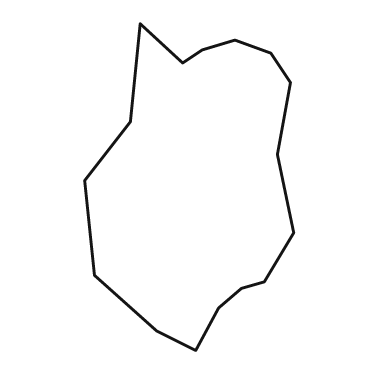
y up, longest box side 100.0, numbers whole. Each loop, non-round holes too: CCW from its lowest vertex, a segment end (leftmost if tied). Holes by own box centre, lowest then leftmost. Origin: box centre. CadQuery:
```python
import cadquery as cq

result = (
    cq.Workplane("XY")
    .moveTo(2.0, -50.0)
    .lineTo(9.0, -37.0)
    .lineTo(16.0, -31.0)
    .lineTo(23.0, -29.0)
    .lineTo(32.0, -14.0)
    .lineTo(27.0, 10.0)
    .lineTo(31.0, 32.0)
    .lineTo(25.0, 41.0)
    .lineTo(14.0, 45.0)
    .lineTo(4.0, 42.0)
    .lineTo(-2.0, 38.0)
    .lineTo(-15.0, 50.0)
    .lineTo(-18.0, 20.0)
    .lineTo(-32.0, 2.0)
    .lineTo(-29.0, -27.0)
    .lineTo(-10.0, -44.0)
    .close()
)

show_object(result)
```